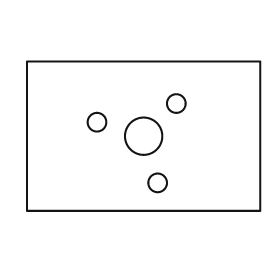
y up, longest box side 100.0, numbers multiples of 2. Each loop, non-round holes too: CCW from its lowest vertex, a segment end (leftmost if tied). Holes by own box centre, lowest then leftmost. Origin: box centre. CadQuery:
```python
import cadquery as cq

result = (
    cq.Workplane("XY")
    .moveTo(-50.0, -32.0)
    .lineTo(50.0, -32.0)
    .lineTo(50.0, 32.0)
    .lineTo(-50.0, 32.0)
    .close()
    .moveTo(6.0, -20.0)
    .circle(4.0)
    .moveTo(0.0, 0.0)
    .circle(8.0)
    .moveTo(-20.0, 6.0)
    .circle(4.0)
    .moveTo(14.0, 14.0)
    .circle(4.0)
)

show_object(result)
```